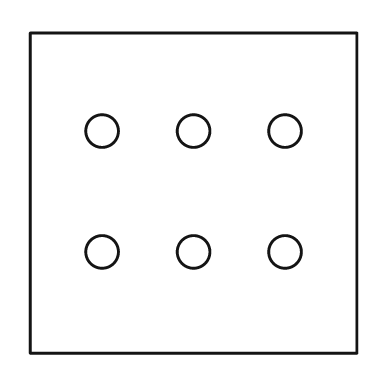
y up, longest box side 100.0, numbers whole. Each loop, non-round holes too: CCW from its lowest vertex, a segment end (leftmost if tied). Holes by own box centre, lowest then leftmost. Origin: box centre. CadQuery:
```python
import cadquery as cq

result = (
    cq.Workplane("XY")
    .moveTo(-50.0, -49.0)
    .lineTo(50.0, -49.0)
    .lineTo(50.0, 49.0)
    .lineTo(-50.0, 49.0)
    .close()
    .moveTo(-28.0, -18.0)
    .circle(5.0)
    .moveTo(0.0, -18.0)
    .circle(5.0)
    .moveTo(28.0, -18.0)
    .circle(5.0)
    .moveTo(-28.0, 19.0)
    .circle(5.0)
    .moveTo(0.0, 19.0)
    .circle(5.0)
    .moveTo(28.0, 19.0)
    .circle(5.0)
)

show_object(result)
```